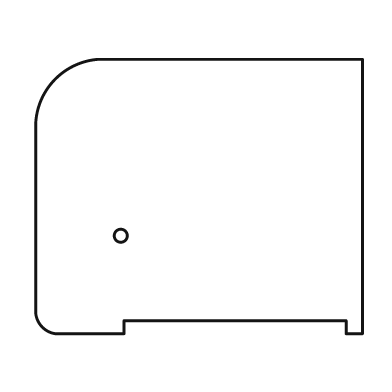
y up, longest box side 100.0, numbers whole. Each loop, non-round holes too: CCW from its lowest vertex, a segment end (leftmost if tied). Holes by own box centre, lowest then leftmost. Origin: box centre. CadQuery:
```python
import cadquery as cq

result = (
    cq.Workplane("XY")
    .moveTo(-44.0, -42.0)
    .lineTo(-23.0, -42.0)
    .lineTo(-23.0, -38.0)
    .lineTo(45.0, -38.0)
    .lineTo(45.0, -42.0)
    .lineTo(50.0, -42.0)
    .lineTo(50.0, 42.0)
    .lineTo(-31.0, 42.0)
    .threePointArc((-44.0, 36.0), (-50.0, 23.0))
    .lineTo(-50.0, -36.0)
    .threePointArc((-48.0, -40.0), (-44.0, -42.0))
    .close()
    .moveTo(-24.0, -12.0)
    .circle(2.0)
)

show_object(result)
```